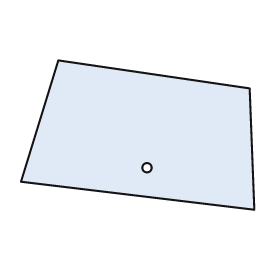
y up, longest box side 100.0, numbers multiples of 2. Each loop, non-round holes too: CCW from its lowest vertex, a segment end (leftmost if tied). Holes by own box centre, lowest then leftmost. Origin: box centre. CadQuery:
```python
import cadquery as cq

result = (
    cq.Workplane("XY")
    .moveTo(50.0, -32.0)
    .lineTo(48.0, 20.0)
    .lineTo(-34.0, 32.0)
    .lineTo(-50.0, -20.0)
    .close()
    .moveTo(4.0, -14.0)
    .circle(2.0)
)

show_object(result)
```